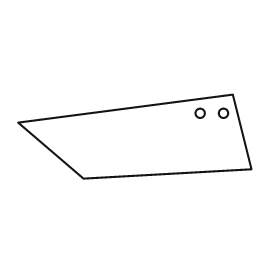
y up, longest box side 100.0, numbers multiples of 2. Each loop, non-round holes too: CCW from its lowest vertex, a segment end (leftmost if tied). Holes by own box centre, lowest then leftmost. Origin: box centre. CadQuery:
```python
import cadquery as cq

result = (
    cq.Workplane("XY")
    .moveTo(-22.0, -18.0)
    .lineTo(50.0, -14.0)
    .lineTo(42.0, 18.0)
    .lineTo(-50.0, 6.0)
    .close()
    .moveTo(28.0, 10.0)
    .circle(2.0)
    .moveTo(38.0, 10.0)
    .circle(2.0)
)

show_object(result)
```